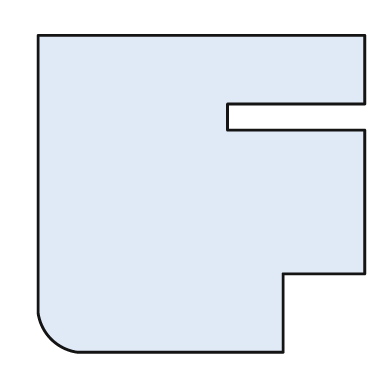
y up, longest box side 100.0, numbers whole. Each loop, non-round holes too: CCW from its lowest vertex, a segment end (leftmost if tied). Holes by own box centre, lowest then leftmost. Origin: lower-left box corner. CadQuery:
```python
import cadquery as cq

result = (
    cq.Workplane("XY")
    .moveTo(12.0, 0.0)
    .lineTo(75.0, 0.0)
    .lineTo(75.0, 24.0)
    .lineTo(100.0, 24.0)
    .lineTo(100.0, 68.0)
    .lineTo(58.0, 68.0)
    .lineTo(58.0, 76.0)
    .lineTo(100.0, 76.0)
    .lineTo(100.0, 97.0)
    .lineTo(0.0, 97.0)
    .lineTo(0.0, 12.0)
    .threePointArc((4.0, 4.0), (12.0, 0.0))
    .close()
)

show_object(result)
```